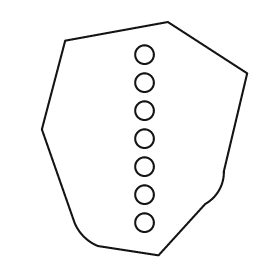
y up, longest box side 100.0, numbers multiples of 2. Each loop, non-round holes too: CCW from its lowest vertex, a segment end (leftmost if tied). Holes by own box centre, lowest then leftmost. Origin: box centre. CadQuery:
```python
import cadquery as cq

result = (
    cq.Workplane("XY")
    .moveTo(6.0, -50.0)
    .lineTo(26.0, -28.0)
    .threePointArc((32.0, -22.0), (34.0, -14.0))
    .lineTo(44.0, 28.0)
    .lineTo(10.0, 50.0)
    .lineTo(-34.0, 42.0)
    .lineTo(-44.0, 4.0)
    .lineTo(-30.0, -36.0)
    .threePointArc((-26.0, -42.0), (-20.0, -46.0))
    .close()
    .moveTo(0.0, -36.0)
    .circle(4.0)
    .moveTo(0.0, -24.0)
    .circle(4.0)
    .moveTo(0.0, -12.0)
    .circle(4.0)
    .moveTo(0.0, 0.0)
    .circle(4.0)
    .moveTo(0.0, 12.0)
    .circle(4.0)
    .moveTo(0.0, 24.0)
    .circle(4.0)
    .moveTo(0.0, 36.0)
    .circle(4.0)
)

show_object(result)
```